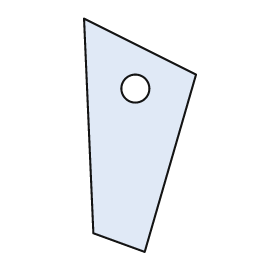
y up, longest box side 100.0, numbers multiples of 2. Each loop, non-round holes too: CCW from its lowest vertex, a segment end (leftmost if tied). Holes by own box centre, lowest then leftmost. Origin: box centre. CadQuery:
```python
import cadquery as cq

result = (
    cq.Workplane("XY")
    .moveTo(2.0, -50.0)
    .lineTo(24.0, 26.0)
    .lineTo(-24.0, 50.0)
    .lineTo(-20.0, -42.0)
    .close()
    .moveTo(-2.0, 20.0)
    .circle(6.0)
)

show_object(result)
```